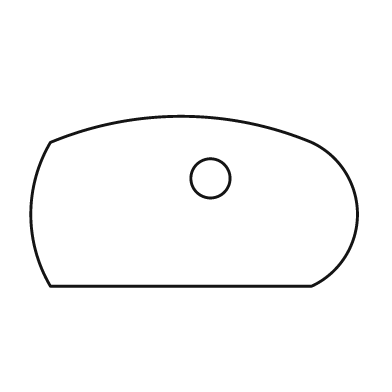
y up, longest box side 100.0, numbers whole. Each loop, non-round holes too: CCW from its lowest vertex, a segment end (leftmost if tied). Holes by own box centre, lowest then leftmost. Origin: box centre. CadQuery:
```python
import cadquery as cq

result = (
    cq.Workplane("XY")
    .moveTo(-44.0, -26.0)
    .lineTo(36.0, -26.0)
    .threePointArc((50.0, -4.0), (36.0, 18.0))
    .threePointArc((-4.0, 26.0), (-44.0, 18.0))
    .threePointArc((-50.0, -4.0), (-44.0, -26.0))
    .close()
    .moveTo(5.0, 7.0)
    .circle(6.0)
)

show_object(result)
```